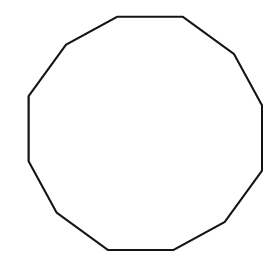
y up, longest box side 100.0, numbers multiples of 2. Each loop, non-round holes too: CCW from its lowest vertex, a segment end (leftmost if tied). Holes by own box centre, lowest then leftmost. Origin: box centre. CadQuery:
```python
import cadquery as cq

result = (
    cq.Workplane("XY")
    .moveTo(-16.0, -50.0)
    .lineTo(12.0, -50.0)
    .lineTo(34.0, -38.0)
    .lineTo(50.0, -16.0)
    .lineTo(50.0, 12.0)
    .lineTo(38.0, 34.0)
    .lineTo(16.0, 50.0)
    .lineTo(-12.0, 50.0)
    .lineTo(-34.0, 38.0)
    .lineTo(-50.0, 16.0)
    .lineTo(-50.0, -12.0)
    .lineTo(-38.0, -34.0)
    .close()
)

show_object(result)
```